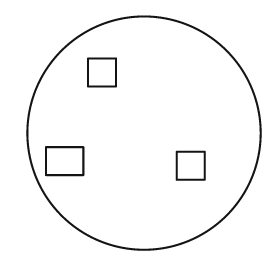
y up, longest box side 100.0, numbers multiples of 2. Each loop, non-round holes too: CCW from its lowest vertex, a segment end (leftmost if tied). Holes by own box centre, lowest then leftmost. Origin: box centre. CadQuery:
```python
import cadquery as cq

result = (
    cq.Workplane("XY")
    .moveTo(0.0, 0.0)
    .circle(50.0)
    .moveTo(14.0, -20.0)
    .lineTo(26.0, -20.0)
    .lineTo(26.0, -8.0)
    .lineTo(14.0, -8.0)
    .close()
    .moveTo(-42.0, -18.0)
    .lineTo(-26.0, -18.0)
    .lineTo(-26.0, -6.0)
    .lineTo(-42.0, -6.0)
    .close()
    .moveTo(-24.0, 20.0)
    .lineTo(-12.0, 20.0)
    .lineTo(-12.0, 32.0)
    .lineTo(-24.0, 32.0)
    .close()
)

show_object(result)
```